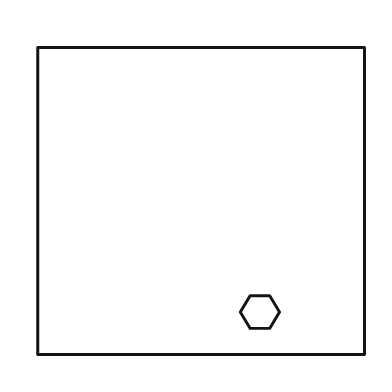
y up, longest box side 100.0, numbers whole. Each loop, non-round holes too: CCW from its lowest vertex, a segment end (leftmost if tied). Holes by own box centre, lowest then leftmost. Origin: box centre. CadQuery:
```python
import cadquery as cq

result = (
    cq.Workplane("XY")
    .moveTo(-50.0, -47.0)
    .lineTo(50.0, -47.0)
    .lineTo(50.0, 47.0)
    .lineTo(-50.0, 47.0)
    .close()
    .moveTo(15.0, -39.0)
    .lineTo(21.0, -39.0)
    .lineTo(24.0, -34.0)
    .lineTo(21.0, -29.0)
    .lineTo(15.0, -29.0)
    .lineTo(12.0, -34.0)
    .close()
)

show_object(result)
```